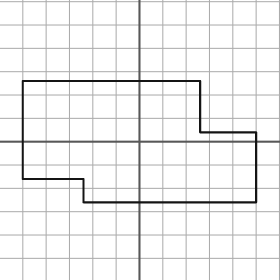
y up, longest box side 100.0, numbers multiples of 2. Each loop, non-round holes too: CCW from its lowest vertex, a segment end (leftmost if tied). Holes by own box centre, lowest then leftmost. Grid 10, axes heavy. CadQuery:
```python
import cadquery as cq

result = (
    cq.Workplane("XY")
    .moveTo(-24.0, -26.0)
    .lineTo(50.0, -26.0)
    .lineTo(50.0, 4.0)
    .lineTo(26.0, 4.0)
    .lineTo(26.0, 26.0)
    .lineTo(-50.0, 26.0)
    .lineTo(-50.0, -16.0)
    .lineTo(-24.0, -16.0)
    .close()
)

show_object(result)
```